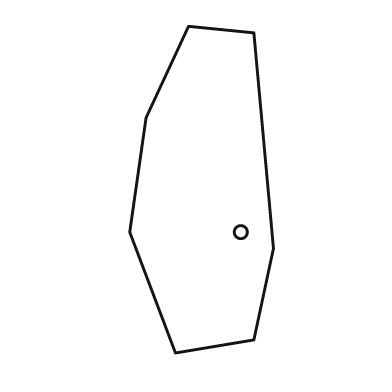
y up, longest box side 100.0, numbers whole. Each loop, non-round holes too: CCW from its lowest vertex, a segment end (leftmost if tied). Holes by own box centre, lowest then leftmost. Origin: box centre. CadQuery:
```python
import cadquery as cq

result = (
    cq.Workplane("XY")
    .moveTo(-8.0, -50.0)
    .lineTo(16.0, -46.0)
    .lineTo(22.0, -18.0)
    .lineTo(16.0, 48.0)
    .lineTo(-4.0, 50.0)
    .lineTo(-17.0, 22.0)
    .lineTo(-22.0, -13.0)
    .close()
    .moveTo(12.0, -13.0)
    .circle(2.0)
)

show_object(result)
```